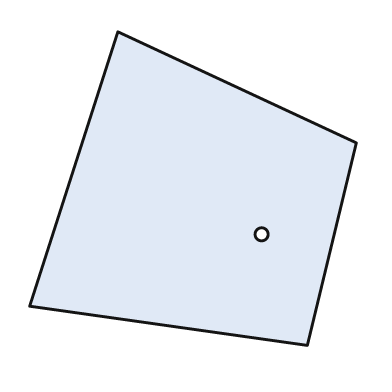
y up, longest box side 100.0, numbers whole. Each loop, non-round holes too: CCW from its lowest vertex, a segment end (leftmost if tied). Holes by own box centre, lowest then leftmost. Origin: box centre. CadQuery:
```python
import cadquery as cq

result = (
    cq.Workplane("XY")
    .moveTo(35.0, -48.0)
    .lineTo(50.0, 14.0)
    .lineTo(-23.0, 48.0)
    .lineTo(-50.0, -36.0)
    .close()
    .moveTo(21.0, -14.0)
    .circle(2.0)
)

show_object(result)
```